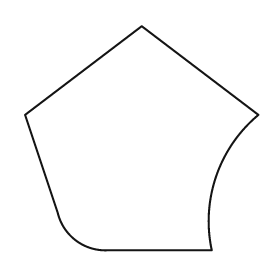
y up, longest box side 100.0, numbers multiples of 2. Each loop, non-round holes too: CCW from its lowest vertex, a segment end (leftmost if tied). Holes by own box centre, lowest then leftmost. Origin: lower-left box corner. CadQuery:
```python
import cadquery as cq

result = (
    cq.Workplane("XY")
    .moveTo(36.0, 0.0)
    .lineTo(80.0, 0.0)
    .threePointArc((82.0, 32.0), (100.0, 58.0))
    .lineTo(50.0, 96.0)
    .lineTo(0.0, 58.0)
    .lineTo(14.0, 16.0)
    .threePointArc((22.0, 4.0), (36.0, 0.0))
    .close()
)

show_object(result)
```